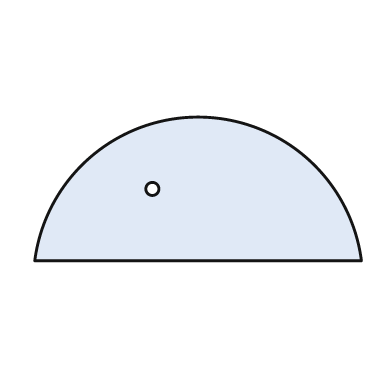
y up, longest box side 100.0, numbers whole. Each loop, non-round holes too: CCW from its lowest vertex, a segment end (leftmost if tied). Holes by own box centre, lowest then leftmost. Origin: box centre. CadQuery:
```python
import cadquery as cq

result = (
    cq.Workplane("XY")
    .moveTo(-50.0, -22.0)
    .lineTo(50.0, -22.0)
    .threePointArc((0.0, 22.0), (-50.0, -22.0))
    .close()
    .moveTo(-14.0, 0.0)
    .circle(2.0)
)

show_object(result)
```